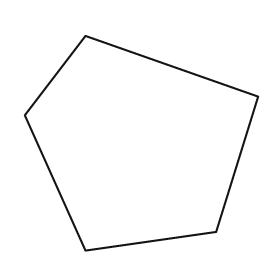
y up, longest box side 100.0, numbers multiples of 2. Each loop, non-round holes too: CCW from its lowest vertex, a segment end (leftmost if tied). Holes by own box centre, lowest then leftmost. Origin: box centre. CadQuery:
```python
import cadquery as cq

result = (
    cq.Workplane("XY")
    .moveTo(-24.0, -46.0)
    .lineTo(32.0, -38.0)
    .lineTo(50.0, 20.0)
    .lineTo(-24.0, 46.0)
    .lineTo(-50.0, 12.0)
    .close()
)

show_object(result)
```